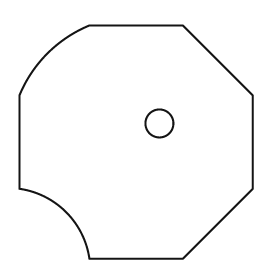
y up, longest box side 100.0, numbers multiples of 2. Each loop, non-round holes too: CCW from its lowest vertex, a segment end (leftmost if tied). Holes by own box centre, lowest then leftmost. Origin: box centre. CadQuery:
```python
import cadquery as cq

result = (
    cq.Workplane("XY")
    .moveTo(-20.0, -50.0)
    .lineTo(20.0, -50.0)
    .lineTo(50.0, -20.0)
    .lineTo(50.0, 20.0)
    .lineTo(20.0, 50.0)
    .lineTo(-20.0, 50.0)
    .threePointArc((-38.0, 38.0), (-50.0, 20.0))
    .lineTo(-50.0, -20.0)
    .threePointArc((-30.0, -30.0), (-20.0, -50.0))
    .close()
    .moveTo(10.0, 8.0)
    .circle(6.0)
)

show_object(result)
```